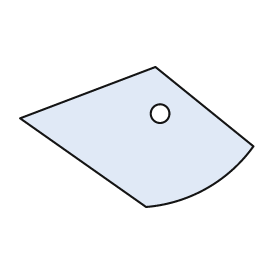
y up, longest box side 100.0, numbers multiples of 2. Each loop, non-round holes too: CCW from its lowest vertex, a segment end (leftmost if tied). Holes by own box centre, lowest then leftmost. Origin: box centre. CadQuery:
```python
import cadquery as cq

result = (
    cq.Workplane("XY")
    .moveTo(4.0, -30.0)
    .threePointArc((30.0, -22.0), (50.0, -4.0))
    .lineTo(8.0, 30.0)
    .lineTo(-50.0, 8.0)
    .close()
    .moveTo(10.0, 10.0)
    .circle(4.0)
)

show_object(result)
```